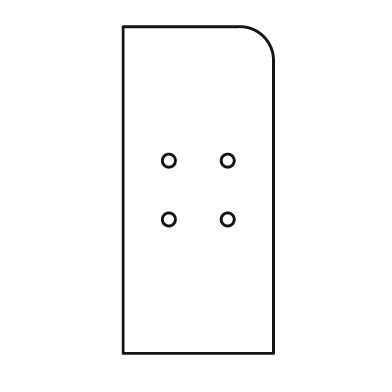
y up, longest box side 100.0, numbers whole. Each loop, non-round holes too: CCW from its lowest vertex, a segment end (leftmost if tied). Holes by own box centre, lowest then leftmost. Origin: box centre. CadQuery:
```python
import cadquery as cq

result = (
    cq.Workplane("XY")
    .moveTo(-23.0, -50.0)
    .lineTo(23.0, -50.0)
    .lineTo(23.0, 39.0)
    .threePointArc((20.0, 47.0), (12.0, 50.0))
    .lineTo(-23.0, 50.0)
    .close()
    .moveTo(-9.0, -9.0)
    .circle(2.0)
    .moveTo(9.0, -9.0)
    .circle(2.0)
    .moveTo(-9.0, 9.0)
    .circle(2.0)
    .moveTo(9.0, 9.0)
    .circle(2.0)
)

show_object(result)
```